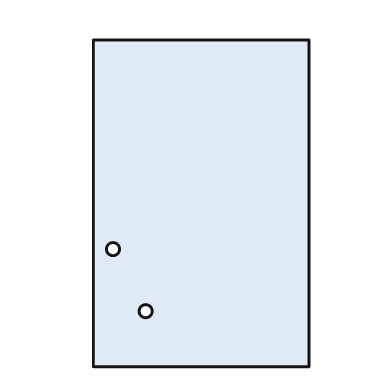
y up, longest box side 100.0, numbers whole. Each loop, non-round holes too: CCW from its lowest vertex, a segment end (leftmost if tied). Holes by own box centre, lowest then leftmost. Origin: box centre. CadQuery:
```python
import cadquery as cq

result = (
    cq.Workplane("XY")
    .moveTo(-33.0, -50.0)
    .lineTo(33.0, -50.0)
    .lineTo(33.0, 50.0)
    .lineTo(-33.0, 50.0)
    .close()
    .moveTo(-17.0, -33.0)
    .circle(2.0)
    .moveTo(-27.0, -14.0)
    .circle(2.0)
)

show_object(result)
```